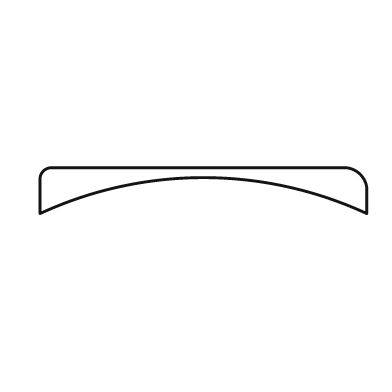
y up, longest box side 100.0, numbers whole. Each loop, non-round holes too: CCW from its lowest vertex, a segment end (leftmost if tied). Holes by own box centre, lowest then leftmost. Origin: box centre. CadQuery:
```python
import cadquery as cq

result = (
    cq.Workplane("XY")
    .moveTo(-50.0, -7.0)
    .threePointArc((0.0, 4.0), (50.0, -7.0))
    .lineTo(50.0, 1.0)
    .threePointArc((48.0, 5.0), (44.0, 7.0))
    .lineTo(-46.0, 7.0)
    .threePointArc((-49.0, 6.0), (-50.0, 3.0))
    .close()
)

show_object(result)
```